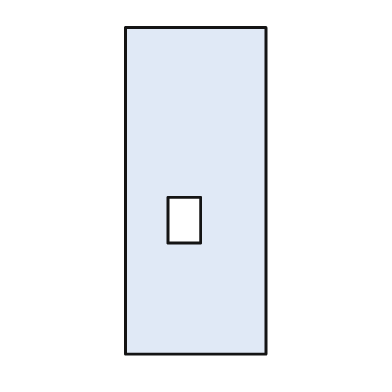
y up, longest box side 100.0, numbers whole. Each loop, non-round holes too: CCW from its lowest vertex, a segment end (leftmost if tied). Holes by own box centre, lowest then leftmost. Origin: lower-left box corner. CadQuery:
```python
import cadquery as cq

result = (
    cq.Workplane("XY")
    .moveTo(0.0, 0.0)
    .lineTo(43.0, 0.0)
    .lineTo(43.0, 100.0)
    .lineTo(0.0, 100.0)
    .close()
    .moveTo(13.0, 34.0)
    .lineTo(23.0, 34.0)
    .lineTo(23.0, 48.0)
    .lineTo(13.0, 48.0)
    .close()
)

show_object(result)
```